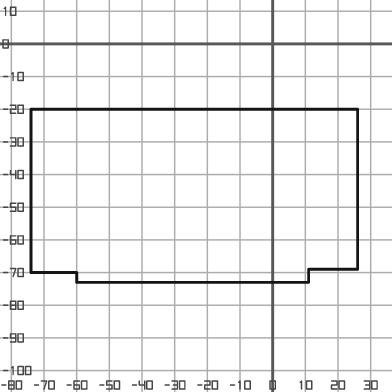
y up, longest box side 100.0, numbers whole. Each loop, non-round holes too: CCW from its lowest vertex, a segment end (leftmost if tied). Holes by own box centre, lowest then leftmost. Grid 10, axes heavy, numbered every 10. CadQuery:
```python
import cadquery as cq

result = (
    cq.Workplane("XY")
    .moveTo(-60.0, -73.0)
    .lineTo(11.0, -73.0)
    .lineTo(11.0, -69.0)
    .lineTo(26.0, -69.0)
    .lineTo(26.0, -20.0)
    .lineTo(-74.0, -20.0)
    .lineTo(-74.0, -70.0)
    .lineTo(-60.0, -70.0)
    .close()
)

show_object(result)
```